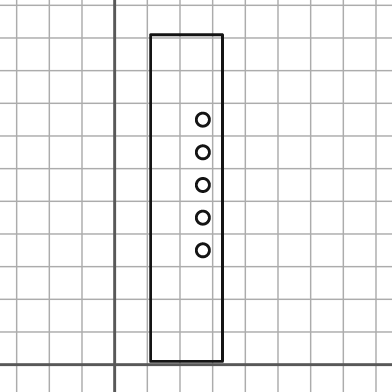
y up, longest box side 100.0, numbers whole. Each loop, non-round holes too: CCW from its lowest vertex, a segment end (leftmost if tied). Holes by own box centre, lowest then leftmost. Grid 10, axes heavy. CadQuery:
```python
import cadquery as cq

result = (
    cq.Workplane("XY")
    .moveTo(11.0, 1.0)
    .lineTo(33.0, 1.0)
    .lineTo(33.0, 101.0)
    .lineTo(11.0, 101.0)
    .close()
    .moveTo(27.0, 35.0)
    .circle(2.0)
    .moveTo(27.0, 45.0)
    .circle(2.0)
    .moveTo(27.0, 55.0)
    .circle(2.0)
    .moveTo(27.0, 65.0)
    .circle(2.0)
    .moveTo(27.0, 75.0)
    .circle(2.0)
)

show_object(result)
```